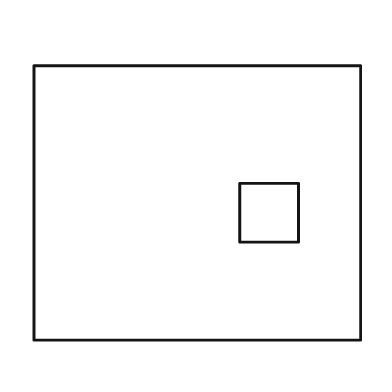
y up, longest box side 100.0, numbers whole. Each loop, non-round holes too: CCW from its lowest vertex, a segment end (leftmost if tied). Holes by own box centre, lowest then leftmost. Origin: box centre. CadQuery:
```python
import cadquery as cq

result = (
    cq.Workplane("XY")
    .moveTo(-50.0, -42.0)
    .lineTo(50.0, -42.0)
    .lineTo(50.0, 42.0)
    .lineTo(-50.0, 42.0)
    .close()
    .moveTo(13.0, -12.0)
    .lineTo(31.0, -12.0)
    .lineTo(31.0, 6.0)
    .lineTo(13.0, 6.0)
    .close()
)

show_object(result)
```